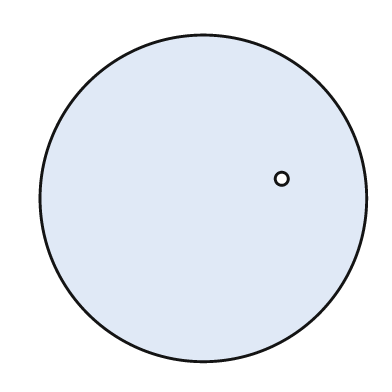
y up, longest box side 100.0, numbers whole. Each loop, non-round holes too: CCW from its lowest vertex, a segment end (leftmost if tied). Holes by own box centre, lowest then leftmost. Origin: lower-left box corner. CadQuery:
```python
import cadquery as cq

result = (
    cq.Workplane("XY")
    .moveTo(50.0, 50.0)
    .circle(50.0)
    .moveTo(74.0, 56.0)
    .circle(2.0)
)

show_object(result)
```